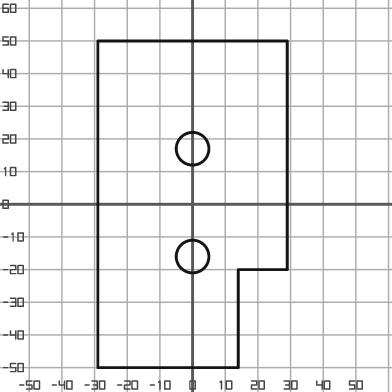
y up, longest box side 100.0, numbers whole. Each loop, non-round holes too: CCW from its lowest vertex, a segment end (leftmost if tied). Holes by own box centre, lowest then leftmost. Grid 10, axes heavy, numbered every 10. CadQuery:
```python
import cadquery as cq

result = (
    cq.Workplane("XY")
    .moveTo(-29.0, -50.0)
    .lineTo(14.0, -50.0)
    .lineTo(14.0, -20.0)
    .lineTo(29.0, -20.0)
    .lineTo(29.0, 50.0)
    .lineTo(-29.0, 50.0)
    .close()
    .moveTo(0.0, -16.0)
    .circle(5.0)
    .moveTo(0.0, 17.0)
    .circle(5.0)
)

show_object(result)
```